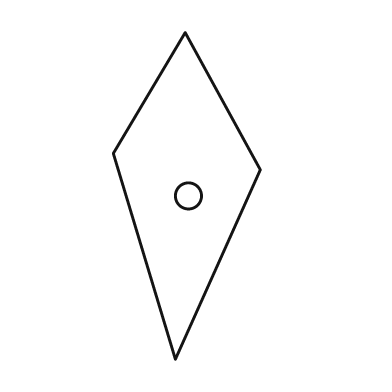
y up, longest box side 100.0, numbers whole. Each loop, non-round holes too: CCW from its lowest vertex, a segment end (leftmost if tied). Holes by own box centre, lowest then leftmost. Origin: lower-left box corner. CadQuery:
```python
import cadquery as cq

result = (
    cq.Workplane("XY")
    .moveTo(19.0, 0.0)
    .lineTo(45.0, 58.0)
    .lineTo(22.0, 100.0)
    .lineTo(0.0, 63.0)
    .close()
    .moveTo(23.0, 50.0)
    .circle(4.0)
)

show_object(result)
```